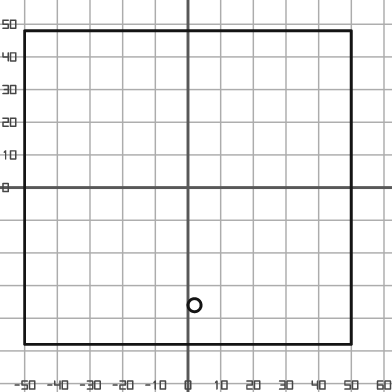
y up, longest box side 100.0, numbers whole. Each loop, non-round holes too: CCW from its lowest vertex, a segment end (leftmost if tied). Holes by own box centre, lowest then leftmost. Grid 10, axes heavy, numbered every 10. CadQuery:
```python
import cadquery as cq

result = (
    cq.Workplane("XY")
    .moveTo(-50.0, -48.0)
    .lineTo(50.0, -48.0)
    .lineTo(50.0, 48.0)
    .lineTo(-50.0, 48.0)
    .close()
    .moveTo(2.0, -36.0)
    .circle(2.0)
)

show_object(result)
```